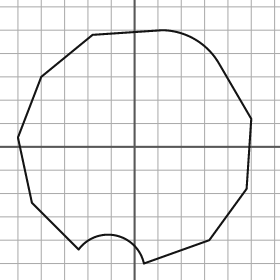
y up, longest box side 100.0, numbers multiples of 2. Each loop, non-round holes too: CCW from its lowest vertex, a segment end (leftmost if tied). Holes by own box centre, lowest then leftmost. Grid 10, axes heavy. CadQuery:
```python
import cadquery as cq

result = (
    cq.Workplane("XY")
    .moveTo(4.0, -50.0)
    .lineTo(32.0, -40.0)
    .lineTo(48.0, -18.0)
    .lineTo(50.0, 12.0)
    .lineTo(36.0, 36.0)
    .threePointArc((26.0, 46.0), (12.0, 50.0))
    .lineTo(-18.0, 48.0)
    .lineTo(-40.0, 30.0)
    .lineTo(-50.0, 4.0)
    .lineTo(-44.0, -24.0)
    .lineTo(-24.0, -44.0)
    .threePointArc((-8.0, -38.0), (4.0, -50.0))
    .close()
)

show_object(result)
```